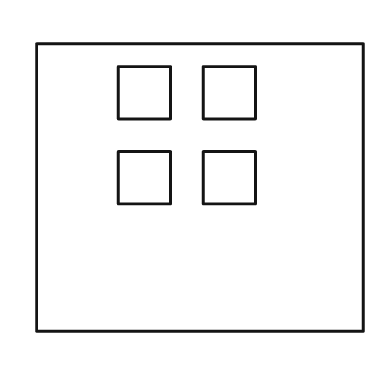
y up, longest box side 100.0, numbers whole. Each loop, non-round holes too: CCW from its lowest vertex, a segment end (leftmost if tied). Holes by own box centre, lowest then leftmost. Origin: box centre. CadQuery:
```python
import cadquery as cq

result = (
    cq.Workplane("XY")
    .moveTo(-50.0, -44.0)
    .lineTo(50.0, -44.0)
    .lineTo(50.0, 44.0)
    .lineTo(-50.0, 44.0)
    .close()
    .moveTo(-25.0, -5.0)
    .lineTo(-9.0, -5.0)
    .lineTo(-9.0, 11.0)
    .lineTo(-25.0, 11.0)
    .close()
    .moveTo(1.0, -5.0)
    .lineTo(17.0, -5.0)
    .lineTo(17.0, 11.0)
    .lineTo(1.0, 11.0)
    .close()
    .moveTo(-25.0, 21.0)
    .lineTo(-9.0, 21.0)
    .lineTo(-9.0, 37.0)
    .lineTo(-25.0, 37.0)
    .close()
    .moveTo(1.0, 21.0)
    .lineTo(17.0, 21.0)
    .lineTo(17.0, 37.0)
    .lineTo(1.0, 37.0)
    .close()
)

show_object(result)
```